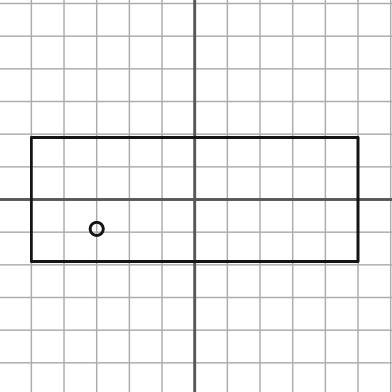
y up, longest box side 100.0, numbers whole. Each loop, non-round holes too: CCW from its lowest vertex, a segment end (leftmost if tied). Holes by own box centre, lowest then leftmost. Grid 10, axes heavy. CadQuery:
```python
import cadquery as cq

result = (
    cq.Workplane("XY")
    .moveTo(-50.0, -19.0)
    .lineTo(50.0, -19.0)
    .lineTo(50.0, 19.0)
    .lineTo(-50.0, 19.0)
    .close()
    .moveTo(-30.0, -9.0)
    .circle(2.0)
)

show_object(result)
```